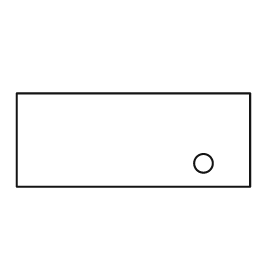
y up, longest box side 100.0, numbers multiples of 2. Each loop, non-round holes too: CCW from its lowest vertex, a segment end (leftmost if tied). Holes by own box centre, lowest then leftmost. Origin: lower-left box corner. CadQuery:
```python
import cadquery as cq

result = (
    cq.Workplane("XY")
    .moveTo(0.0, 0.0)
    .lineTo(100.0, 0.0)
    .lineTo(100.0, 40.0)
    .lineTo(0.0, 40.0)
    .close()
    .moveTo(80.0, 10.0)
    .circle(4.0)
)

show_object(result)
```